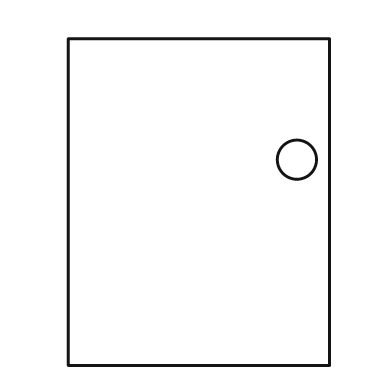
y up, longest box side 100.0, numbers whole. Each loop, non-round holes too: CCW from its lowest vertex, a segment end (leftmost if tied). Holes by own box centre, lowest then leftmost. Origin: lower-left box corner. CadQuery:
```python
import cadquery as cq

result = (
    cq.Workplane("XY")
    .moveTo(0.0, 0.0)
    .lineTo(80.0, 0.0)
    .lineTo(80.0, 100.0)
    .lineTo(0.0, 100.0)
    .close()
    .moveTo(70.0, 63.0)
    .circle(6.0)
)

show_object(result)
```